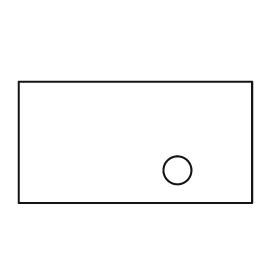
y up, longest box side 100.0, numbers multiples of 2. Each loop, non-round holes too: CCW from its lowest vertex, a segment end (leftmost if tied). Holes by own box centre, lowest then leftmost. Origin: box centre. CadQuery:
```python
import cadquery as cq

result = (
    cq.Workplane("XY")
    .moveTo(-50.0, -26.0)
    .lineTo(50.0, -26.0)
    .lineTo(50.0, 26.0)
    .lineTo(-50.0, 26.0)
    .close()
    .moveTo(18.0, -12.0)
    .circle(6.0)
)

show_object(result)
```